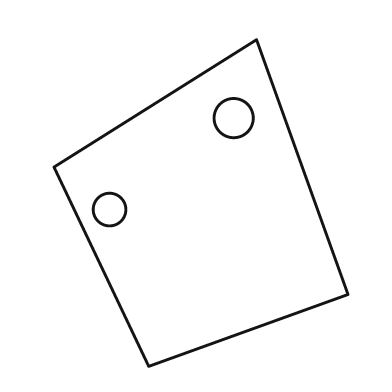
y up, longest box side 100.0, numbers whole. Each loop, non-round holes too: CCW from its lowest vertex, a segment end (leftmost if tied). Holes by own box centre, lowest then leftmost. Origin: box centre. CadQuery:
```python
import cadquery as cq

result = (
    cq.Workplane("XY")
    .moveTo(-16.0, -50.0)
    .lineTo(45.0, -28.0)
    .lineTo(17.0, 50.0)
    .lineTo(-45.0, 11.0)
    .close()
    .moveTo(-28.0, -2.0)
    .circle(5.0)
    .moveTo(10.0, 26.0)
    .circle(6.0)
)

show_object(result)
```